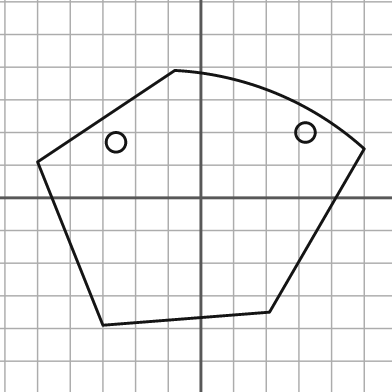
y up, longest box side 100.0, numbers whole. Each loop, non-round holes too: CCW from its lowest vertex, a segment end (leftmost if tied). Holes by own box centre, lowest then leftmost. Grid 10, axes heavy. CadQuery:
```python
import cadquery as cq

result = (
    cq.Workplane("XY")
    .moveTo(-30.0, -39.0)
    .lineTo(21.0, -35.0)
    .lineTo(50.0, 15.0)
    .threePointArc((23.0, 32.0), (-8.0, 39.0))
    .lineTo(-50.0, 11.0)
    .close()
    .moveTo(-26.0, 17.0)
    .circle(3.0)
    .moveTo(32.0, 20.0)
    .circle(3.0)
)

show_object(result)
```